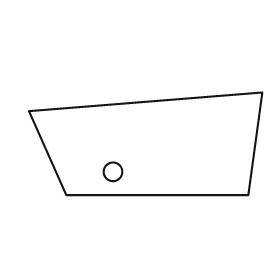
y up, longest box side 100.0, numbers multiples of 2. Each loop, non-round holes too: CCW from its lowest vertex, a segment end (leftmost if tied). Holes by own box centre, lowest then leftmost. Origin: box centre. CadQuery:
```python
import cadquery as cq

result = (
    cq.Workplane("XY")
    .moveTo(-34.0, -22.0)
    .lineTo(44.0, -22.0)
    .lineTo(50.0, 22.0)
    .lineTo(-50.0, 14.0)
    .close()
    .moveTo(-14.0, -12.0)
    .circle(4.0)
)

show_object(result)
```